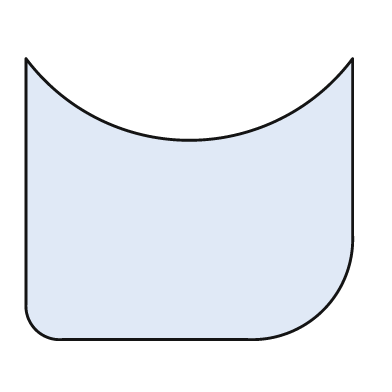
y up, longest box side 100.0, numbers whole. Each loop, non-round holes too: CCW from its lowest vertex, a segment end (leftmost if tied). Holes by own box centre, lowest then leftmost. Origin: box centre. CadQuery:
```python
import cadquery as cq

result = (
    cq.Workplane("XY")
    .moveTo(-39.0, -43.0)
    .lineTo(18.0, -43.0)
    .threePointArc((41.0, -34.0), (50.0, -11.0))
    .lineTo(50.0, 43.0)
    .threePointArc((0.0, 18.0), (-50.0, 43.0))
    .lineTo(-50.0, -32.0)
    .threePointArc((-47.0, -40.0), (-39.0, -43.0))
    .close()
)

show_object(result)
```